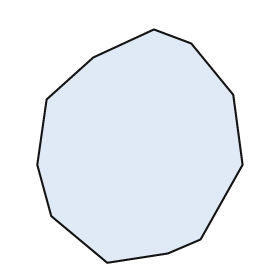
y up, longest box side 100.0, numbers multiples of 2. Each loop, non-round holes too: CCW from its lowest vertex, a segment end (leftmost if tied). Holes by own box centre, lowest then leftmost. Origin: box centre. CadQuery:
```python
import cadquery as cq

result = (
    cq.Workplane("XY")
    .moveTo(-14.0, -50.0)
    .lineTo(12.0, -46.0)
    .lineTo(26.0, -40.0)
    .lineTo(44.0, -8.0)
    .lineTo(40.0, 22.0)
    .lineTo(22.0, 44.0)
    .lineTo(6.0, 50.0)
    .lineTo(-20.0, 38.0)
    .lineTo(-40.0, 20.0)
    .lineTo(-44.0, -8.0)
    .lineTo(-38.0, -30.0)
    .close()
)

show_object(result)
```